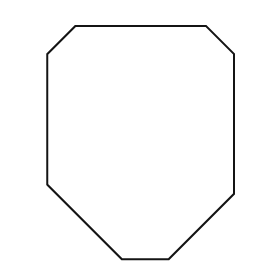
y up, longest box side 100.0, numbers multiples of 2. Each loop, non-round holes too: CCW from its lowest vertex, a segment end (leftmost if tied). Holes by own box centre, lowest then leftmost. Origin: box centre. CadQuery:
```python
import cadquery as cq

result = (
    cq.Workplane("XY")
    .moveTo(-8.0, -50.0)
    .lineTo(12.0, -50.0)
    .lineTo(40.0, -22.0)
    .lineTo(40.0, 38.0)
    .lineTo(28.0, 50.0)
    .lineTo(-28.0, 50.0)
    .lineTo(-40.0, 38.0)
    .lineTo(-40.0, -18.0)
    .close()
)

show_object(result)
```